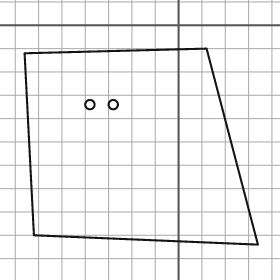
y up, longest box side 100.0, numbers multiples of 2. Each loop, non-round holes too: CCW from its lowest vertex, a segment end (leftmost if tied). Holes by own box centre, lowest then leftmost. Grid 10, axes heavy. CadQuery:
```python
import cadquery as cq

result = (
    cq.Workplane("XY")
    .moveTo(34.0, -94.0)
    .lineTo(12.0, -10.0)
    .lineTo(-66.0, -12.0)
    .lineTo(-62.0, -90.0)
    .close()
    .moveTo(-38.0, -34.0)
    .circle(2.0)
    .moveTo(-28.0, -34.0)
    .circle(2.0)
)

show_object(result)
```